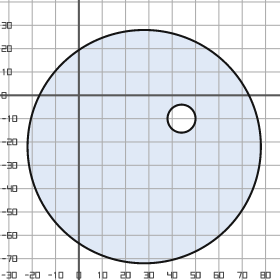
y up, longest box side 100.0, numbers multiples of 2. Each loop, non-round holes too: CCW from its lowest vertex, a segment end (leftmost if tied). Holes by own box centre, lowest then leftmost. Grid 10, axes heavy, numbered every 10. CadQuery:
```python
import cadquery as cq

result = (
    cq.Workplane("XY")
    .moveTo(28.0, -22.0)
    .circle(50.0)
    .moveTo(44.0, -10.0)
    .circle(6.0)
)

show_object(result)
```